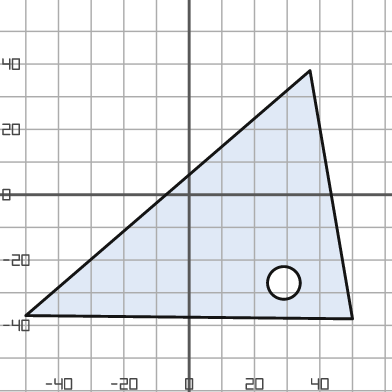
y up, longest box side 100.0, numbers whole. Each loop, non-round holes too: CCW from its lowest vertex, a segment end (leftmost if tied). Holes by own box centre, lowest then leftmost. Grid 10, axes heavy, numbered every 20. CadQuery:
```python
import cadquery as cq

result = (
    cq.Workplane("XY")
    .moveTo(50.0, -38.0)
    .lineTo(37.0, 38.0)
    .lineTo(-50.0, -37.0)
    .close()
    .moveTo(29.0, -27.0)
    .circle(5.0)
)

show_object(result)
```